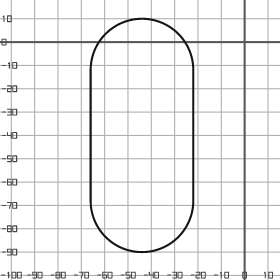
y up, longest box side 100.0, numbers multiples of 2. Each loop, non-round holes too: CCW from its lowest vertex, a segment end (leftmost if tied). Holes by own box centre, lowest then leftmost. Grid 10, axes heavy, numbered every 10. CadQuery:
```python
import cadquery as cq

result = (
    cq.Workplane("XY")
    .moveTo(-66.0, -68.0)
    .threePointArc((-44.0, -90.0), (-22.0, -68.0))
    .lineTo(-22.0, -12.0)
    .threePointArc((-44.0, 10.0), (-66.0, -12.0))
    .close()
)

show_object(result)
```